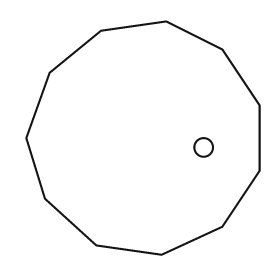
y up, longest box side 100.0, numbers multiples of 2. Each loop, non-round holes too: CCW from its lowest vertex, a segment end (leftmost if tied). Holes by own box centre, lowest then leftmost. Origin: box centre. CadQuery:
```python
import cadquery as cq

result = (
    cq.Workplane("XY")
    .moveTo(8.0, -50.0)
    .lineTo(34.0, -38.0)
    .lineTo(50.0, -14.0)
    .lineTo(50.0, 14.0)
    .lineTo(34.0, 38.0)
    .lineTo(10.0, 50.0)
    .lineTo(-18.0, 46.0)
    .lineTo(-40.0, 28.0)
    .lineTo(-50.0, 0.0)
    .lineTo(-42.0, -26.0)
    .lineTo(-20.0, -46.0)
    .close()
    .moveTo(26.0, -4.0)
    .circle(4.0)
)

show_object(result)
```